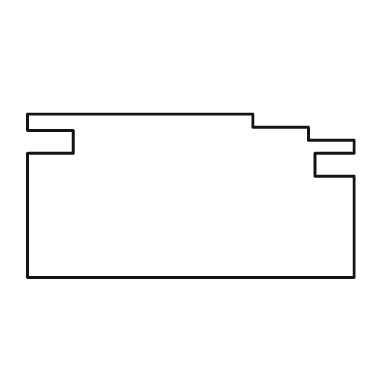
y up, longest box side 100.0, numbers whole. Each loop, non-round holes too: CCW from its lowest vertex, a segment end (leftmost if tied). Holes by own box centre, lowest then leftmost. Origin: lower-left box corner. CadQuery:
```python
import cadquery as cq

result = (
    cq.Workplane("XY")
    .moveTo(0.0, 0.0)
    .lineTo(100.0, 0.0)
    .lineTo(100.0, 31.0)
    .lineTo(88.0, 31.0)
    .lineTo(88.0, 38.0)
    .lineTo(100.0, 38.0)
    .lineTo(100.0, 42.0)
    .lineTo(86.0, 42.0)
    .lineTo(86.0, 46.0)
    .lineTo(69.0, 46.0)
    .lineTo(69.0, 50.0)
    .lineTo(0.0, 50.0)
    .lineTo(0.0, 45.0)
    .lineTo(14.0, 45.0)
    .lineTo(14.0, 38.0)
    .lineTo(0.0, 38.0)
    .close()
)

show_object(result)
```